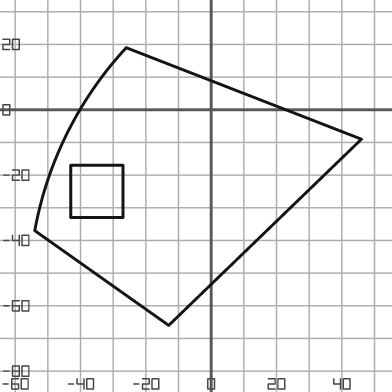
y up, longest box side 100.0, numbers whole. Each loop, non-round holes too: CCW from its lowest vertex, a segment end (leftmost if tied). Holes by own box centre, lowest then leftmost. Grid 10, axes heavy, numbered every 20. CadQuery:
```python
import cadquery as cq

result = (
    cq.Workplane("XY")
    .moveTo(-13.0, -66.0)
    .lineTo(46.0, -9.0)
    .lineTo(-26.0, 19.0)
    .threePointArc((-44.0, -7.0), (-54.0, -37.0))
    .close()
    .moveTo(-43.0, -33.0)
    .lineTo(-27.0, -33.0)
    .lineTo(-27.0, -17.0)
    .lineTo(-43.0, -17.0)
    .close()
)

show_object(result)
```